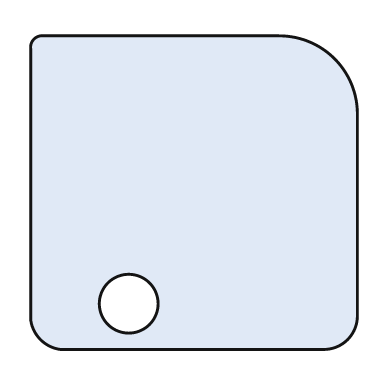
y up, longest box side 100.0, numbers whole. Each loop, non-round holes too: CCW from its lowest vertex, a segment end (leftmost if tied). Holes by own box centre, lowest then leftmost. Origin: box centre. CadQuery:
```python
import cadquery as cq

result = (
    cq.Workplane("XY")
    .moveTo(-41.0, -48.0)
    .lineTo(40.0, -48.0)
    .threePointArc((47.0, -45.0), (50.0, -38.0))
    .lineTo(50.0, 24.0)
    .threePointArc((43.0, 41.0), (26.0, 48.0))
    .lineTo(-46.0, 48.0)
    .threePointArc((-49.0, 47.0), (-50.0, 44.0))
    .lineTo(-50.0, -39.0)
    .threePointArc((-47.0, -45.0), (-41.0, -48.0))
    .close()
    .moveTo(-20.0, -34.0)
    .circle(9.0)
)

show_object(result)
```